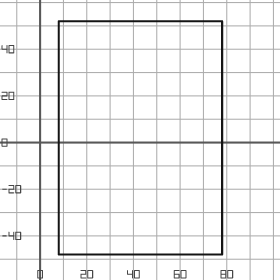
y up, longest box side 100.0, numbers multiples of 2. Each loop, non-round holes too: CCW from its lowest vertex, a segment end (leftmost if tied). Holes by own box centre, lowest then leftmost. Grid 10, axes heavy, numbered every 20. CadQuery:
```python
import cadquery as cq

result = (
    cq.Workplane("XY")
    .moveTo(8.0, -48.0)
    .lineTo(78.0, -48.0)
    .lineTo(78.0, 52.0)
    .lineTo(8.0, 52.0)
    .close()
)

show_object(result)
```